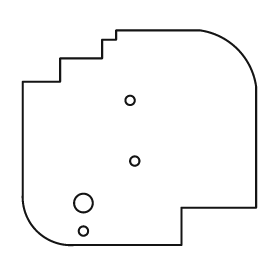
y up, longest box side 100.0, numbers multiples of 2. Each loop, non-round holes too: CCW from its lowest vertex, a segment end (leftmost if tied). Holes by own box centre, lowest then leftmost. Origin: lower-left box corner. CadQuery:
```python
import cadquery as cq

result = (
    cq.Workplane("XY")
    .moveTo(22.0, 0.0)
    .lineTo(68.0, 0.0)
    .lineTo(68.0, 16.0)
    .lineTo(100.0, 16.0)
    .lineTo(100.0, 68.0)
    .threePointArc((92.0, 84.0), (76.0, 92.0))
    .lineTo(40.0, 92.0)
    .lineTo(40.0, 88.0)
    .lineTo(34.0, 88.0)
    .lineTo(34.0, 80.0)
    .lineTo(16.0, 80.0)
    .lineTo(16.0, 70.0)
    .lineTo(0.0, 70.0)
    .lineTo(0.0, 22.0)
    .threePointArc((6.0, 6.0), (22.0, 0.0))
    .close()
    .moveTo(26.0, 6.0)
    .circle(2.0)
    .moveTo(26.0, 18.0)
    .circle(4.0)
    .moveTo(48.0, 36.0)
    .circle(2.0)
    .moveTo(46.0, 62.0)
    .circle(2.0)
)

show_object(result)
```